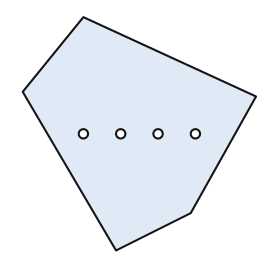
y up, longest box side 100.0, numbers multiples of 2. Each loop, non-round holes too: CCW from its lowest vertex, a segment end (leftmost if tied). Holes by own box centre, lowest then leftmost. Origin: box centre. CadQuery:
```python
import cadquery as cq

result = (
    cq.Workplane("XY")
    .moveTo(-10.0, -50.0)
    .lineTo(22.0, -34.0)
    .lineTo(50.0, 16.0)
    .lineTo(-24.0, 50.0)
    .lineTo(-50.0, 18.0)
    .close()
    .moveTo(-24.0, 0.0)
    .circle(2.0)
    .moveTo(-8.0, 0.0)
    .circle(2.0)
    .moveTo(8.0, 0.0)
    .circle(2.0)
    .moveTo(24.0, 0.0)
    .circle(2.0)
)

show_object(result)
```